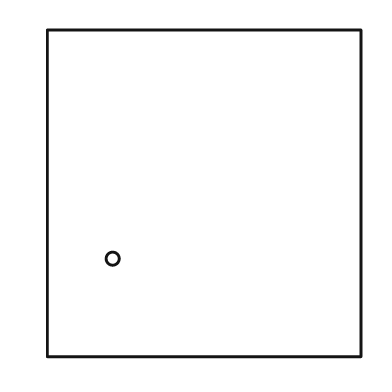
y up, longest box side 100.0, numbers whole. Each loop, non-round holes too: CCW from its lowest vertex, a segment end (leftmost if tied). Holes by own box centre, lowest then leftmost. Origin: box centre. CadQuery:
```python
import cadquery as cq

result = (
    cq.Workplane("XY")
    .moveTo(-48.0, -50.0)
    .lineTo(48.0, -50.0)
    .lineTo(48.0, 50.0)
    .lineTo(-48.0, 50.0)
    .close()
    .moveTo(-28.0, -20.0)
    .circle(2.0)
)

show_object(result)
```